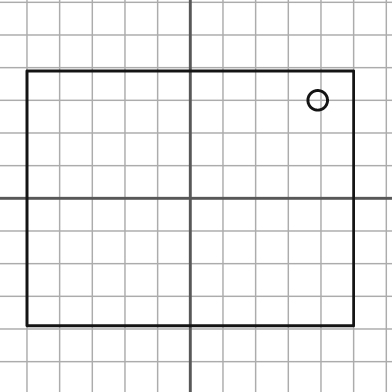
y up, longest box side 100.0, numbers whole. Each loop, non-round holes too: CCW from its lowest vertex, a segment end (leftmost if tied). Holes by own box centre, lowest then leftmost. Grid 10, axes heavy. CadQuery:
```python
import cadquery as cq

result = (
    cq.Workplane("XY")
    .moveTo(-50.0, -39.0)
    .lineTo(50.0, -39.0)
    .lineTo(50.0, 39.0)
    .lineTo(-50.0, 39.0)
    .close()
    .moveTo(39.0, 30.0)
    .circle(3.0)
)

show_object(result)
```